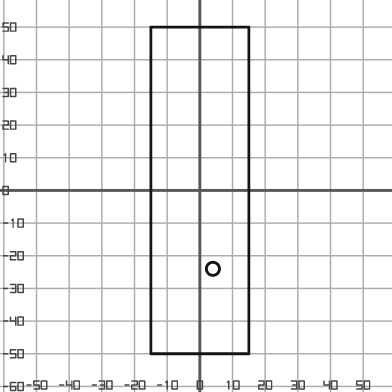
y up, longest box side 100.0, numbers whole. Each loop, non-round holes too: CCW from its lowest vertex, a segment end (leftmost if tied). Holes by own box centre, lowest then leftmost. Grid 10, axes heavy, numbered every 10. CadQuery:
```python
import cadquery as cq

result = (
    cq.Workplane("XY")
    .moveTo(-15.0, -50.0)
    .lineTo(15.0, -50.0)
    .lineTo(15.0, 50.0)
    .lineTo(-15.0, 50.0)
    .close()
    .moveTo(4.0, -24.0)
    .circle(2.0)
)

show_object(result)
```